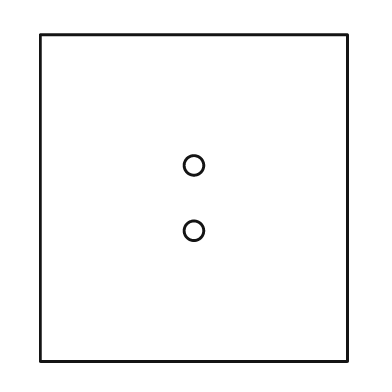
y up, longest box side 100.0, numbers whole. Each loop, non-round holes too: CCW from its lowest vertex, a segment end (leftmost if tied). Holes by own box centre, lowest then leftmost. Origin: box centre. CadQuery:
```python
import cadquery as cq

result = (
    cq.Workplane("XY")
    .moveTo(-47.0, -50.0)
    .lineTo(47.0, -50.0)
    .lineTo(47.0, 50.0)
    .lineTo(-47.0, 50.0)
    .close()
    .moveTo(0.0, -10.0)
    .circle(3.0)
    .moveTo(0.0, 10.0)
    .circle(3.0)
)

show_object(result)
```